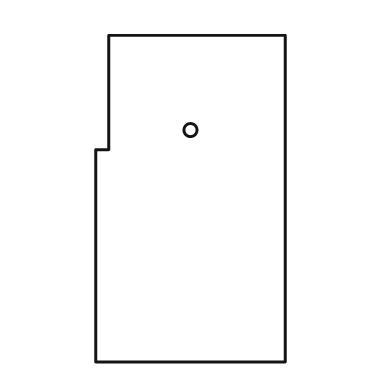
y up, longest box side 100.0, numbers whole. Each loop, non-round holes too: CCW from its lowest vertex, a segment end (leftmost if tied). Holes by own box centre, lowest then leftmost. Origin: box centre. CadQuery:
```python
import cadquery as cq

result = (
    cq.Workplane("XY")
    .moveTo(-29.0, -50.0)
    .lineTo(29.0, -50.0)
    .lineTo(29.0, 50.0)
    .lineTo(-25.0, 50.0)
    .lineTo(-25.0, 15.0)
    .lineTo(-29.0, 15.0)
    .close()
    .moveTo(0.0, 21.0)
    .circle(2.0)
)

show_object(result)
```